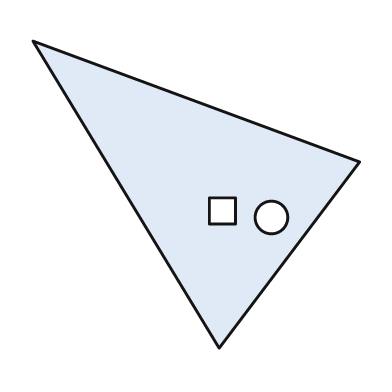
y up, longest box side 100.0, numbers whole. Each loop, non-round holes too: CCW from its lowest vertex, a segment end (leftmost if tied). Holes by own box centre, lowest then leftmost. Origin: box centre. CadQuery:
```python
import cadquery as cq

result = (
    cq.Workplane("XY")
    .moveTo(7.0, -47.0)
    .lineTo(50.0, 10.0)
    .lineTo(-50.0, 47.0)
    .close()
    .moveTo(23.0, -7.0)
    .circle(5.0)
    .moveTo(4.0, -9.0)
    .lineTo(12.0, -9.0)
    .lineTo(12.0, -1.0)
    .lineTo(4.0, -1.0)
    .close()
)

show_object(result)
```